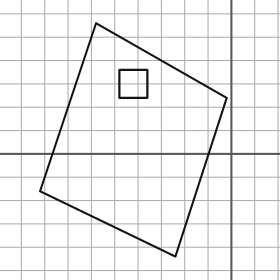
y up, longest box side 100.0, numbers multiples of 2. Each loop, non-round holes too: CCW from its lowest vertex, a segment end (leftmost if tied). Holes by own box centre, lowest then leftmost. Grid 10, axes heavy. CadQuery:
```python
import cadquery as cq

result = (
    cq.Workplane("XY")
    .moveTo(-24.0, -44.0)
    .lineTo(-2.0, 24.0)
    .lineTo(-58.0, 56.0)
    .lineTo(-82.0, -16.0)
    .close()
    .moveTo(-48.0, 24.0)
    .lineTo(-36.0, 24.0)
    .lineTo(-36.0, 36.0)
    .lineTo(-48.0, 36.0)
    .close()
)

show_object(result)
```